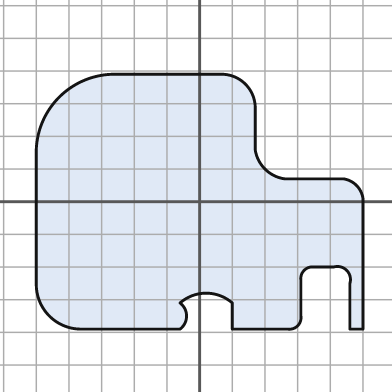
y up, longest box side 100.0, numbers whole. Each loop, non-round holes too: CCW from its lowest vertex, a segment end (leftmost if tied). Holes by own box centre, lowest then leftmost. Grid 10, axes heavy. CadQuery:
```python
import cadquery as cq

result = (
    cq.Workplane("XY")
    .moveTo(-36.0, -39.0)
    .lineTo(-6.0, -39.0)
    .threePointArc((-4.0, -35.0), (-6.0, -31.0))
    .threePointArc((2.0, -28.0), (10.0, -31.0))
    .lineTo(10.0, -39.0)
    .lineTo(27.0, -39.0)
    .threePointArc((30.0, -38.0), (31.0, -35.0))
    .lineTo(31.0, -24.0)
    .threePointArc((32.0, -21.0), (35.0, -20.0))
    .lineTo(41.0, -20.0)
    .threePointArc((45.0, -21.0), (46.0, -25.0))
    .lineTo(46.0, -39.0)
    .lineTo(50.0, -39.0)
    .lineTo(50.0, 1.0)
    .threePointArc((48.0, 5.0), (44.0, 7.0))
    .lineTo(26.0, 7.0)
    .threePointArc((20.0, 10.0), (17.0, 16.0))
    .lineTo(17.0, 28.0)
    .threePointArc((14.0, 36.0), (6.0, 39.0))
    .lineTo(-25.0, 39.0)
    .threePointArc((-43.0, 32.0), (-50.0, 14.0))
    .lineTo(-50.0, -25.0)
    .threePointArc((-46.0, -35.0), (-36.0, -39.0))
    .close()
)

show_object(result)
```